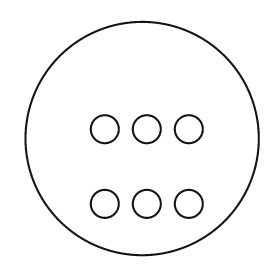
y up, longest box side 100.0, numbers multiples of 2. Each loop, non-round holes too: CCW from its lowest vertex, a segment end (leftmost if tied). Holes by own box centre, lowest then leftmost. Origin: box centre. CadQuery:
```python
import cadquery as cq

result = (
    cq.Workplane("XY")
    .moveTo(0.0, 0.0)
    .circle(50.0)
    .moveTo(-16.0, -28.0)
    .circle(6.0)
    .moveTo(2.0, -28.0)
    .circle(6.0)
    .moveTo(20.0, -28.0)
    .circle(6.0)
    .moveTo(-16.0, 4.0)
    .circle(6.0)
    .moveTo(2.0, 4.0)
    .circle(6.0)
    .moveTo(20.0, 4.0)
    .circle(6.0)
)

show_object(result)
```